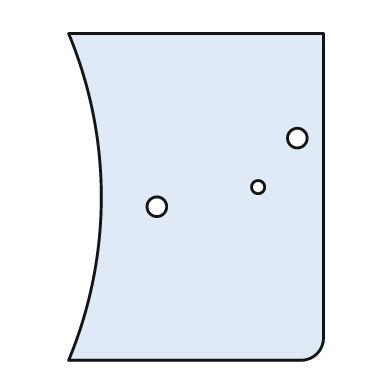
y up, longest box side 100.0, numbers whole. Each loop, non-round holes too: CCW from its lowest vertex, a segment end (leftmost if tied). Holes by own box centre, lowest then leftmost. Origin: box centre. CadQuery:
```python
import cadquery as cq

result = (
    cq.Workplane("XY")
    .moveTo(-39.0, -50.0)
    .lineTo(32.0, -50.0)
    .threePointArc((37.0, -48.0), (39.0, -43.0))
    .lineTo(39.0, 50.0)
    .lineTo(-39.0, 50.0)
    .threePointArc((-29.0, 0.0), (-39.0, -50.0))
    .close()
    .moveTo(-12.0, -3.0)
    .circle(3.0)
    .moveTo(19.0, 3.0)
    .circle(2.0)
    .moveTo(31.0, 18.0)
    .circle(3.0)
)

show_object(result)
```